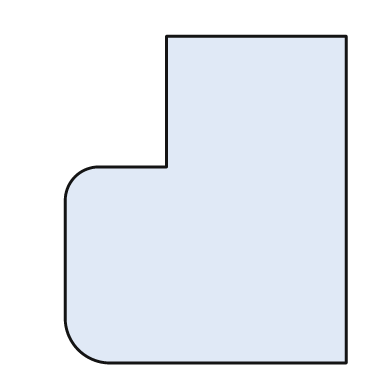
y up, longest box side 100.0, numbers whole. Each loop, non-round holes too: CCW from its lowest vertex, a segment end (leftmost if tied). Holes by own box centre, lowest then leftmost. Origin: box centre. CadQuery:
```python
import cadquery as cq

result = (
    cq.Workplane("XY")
    .moveTo(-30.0, -50.0)
    .lineTo(43.0, -50.0)
    .lineTo(43.0, 50.0)
    .lineTo(-12.0, 50.0)
    .lineTo(-12.0, 10.0)
    .lineTo(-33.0, 10.0)
    .threePointArc((-40.0, 7.0), (-43.0, 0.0))
    .lineTo(-43.0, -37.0)
    .threePointArc((-39.0, -46.0), (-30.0, -50.0))
    .close()
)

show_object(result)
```